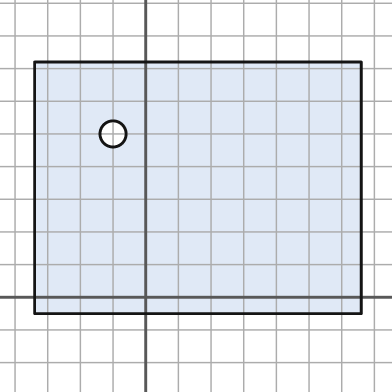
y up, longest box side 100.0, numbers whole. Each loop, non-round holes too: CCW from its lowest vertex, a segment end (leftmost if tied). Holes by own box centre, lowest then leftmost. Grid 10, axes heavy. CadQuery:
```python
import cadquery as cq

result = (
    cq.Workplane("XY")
    .moveTo(-34.0, -5.0)
    .lineTo(66.0, -5.0)
    .lineTo(66.0, 72.0)
    .lineTo(-34.0, 72.0)
    .close()
    .moveTo(-10.0, 50.0)
    .circle(4.0)
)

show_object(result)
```